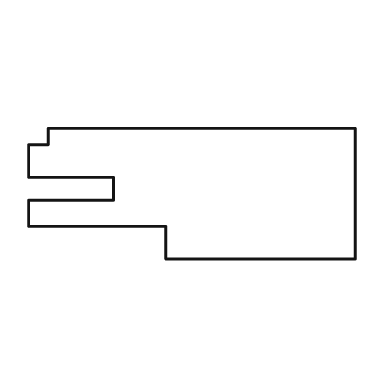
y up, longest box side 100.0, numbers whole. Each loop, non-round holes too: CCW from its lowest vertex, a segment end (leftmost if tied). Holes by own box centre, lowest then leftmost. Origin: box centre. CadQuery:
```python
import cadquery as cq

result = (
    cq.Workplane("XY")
    .moveTo(-8.0, -20.0)
    .lineTo(50.0, -20.0)
    .lineTo(50.0, 20.0)
    .lineTo(-44.0, 20.0)
    .lineTo(-44.0, 15.0)
    .lineTo(-50.0, 15.0)
    .lineTo(-50.0, 5.0)
    .lineTo(-24.0, 5.0)
    .lineTo(-24.0, -2.0)
    .lineTo(-50.0, -2.0)
    .lineTo(-50.0, -10.0)
    .lineTo(-8.0, -10.0)
    .close()
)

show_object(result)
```